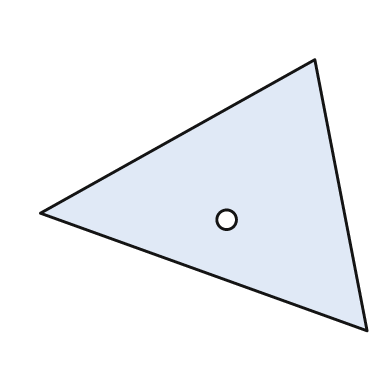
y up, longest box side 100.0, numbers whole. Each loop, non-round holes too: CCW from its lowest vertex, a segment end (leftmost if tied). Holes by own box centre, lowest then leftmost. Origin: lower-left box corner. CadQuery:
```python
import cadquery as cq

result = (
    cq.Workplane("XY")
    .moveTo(100.0, 0.0)
    .lineTo(84.0, 83.0)
    .lineTo(0.0, 36.0)
    .close()
    .moveTo(57.0, 34.0)
    .circle(3.0)
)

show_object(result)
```